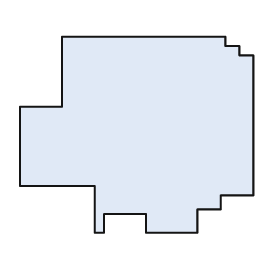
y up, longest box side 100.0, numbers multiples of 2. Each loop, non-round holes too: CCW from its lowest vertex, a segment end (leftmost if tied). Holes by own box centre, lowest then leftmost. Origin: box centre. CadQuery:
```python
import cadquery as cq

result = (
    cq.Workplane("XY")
    .moveTo(-18.0, -42.0)
    .lineTo(-14.0, -42.0)
    .lineTo(-14.0, -34.0)
    .lineTo(4.0, -34.0)
    .lineTo(4.0, -42.0)
    .lineTo(26.0, -42.0)
    .lineTo(26.0, -32.0)
    .lineTo(36.0, -32.0)
    .lineTo(36.0, -26.0)
    .lineTo(50.0, -26.0)
    .lineTo(50.0, 34.0)
    .lineTo(44.0, 34.0)
    .lineTo(44.0, 38.0)
    .lineTo(38.0, 38.0)
    .lineTo(38.0, 42.0)
    .lineTo(-32.0, 42.0)
    .lineTo(-32.0, 12.0)
    .lineTo(-50.0, 12.0)
    .lineTo(-50.0, -22.0)
    .lineTo(-18.0, -22.0)
    .close()
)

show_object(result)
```